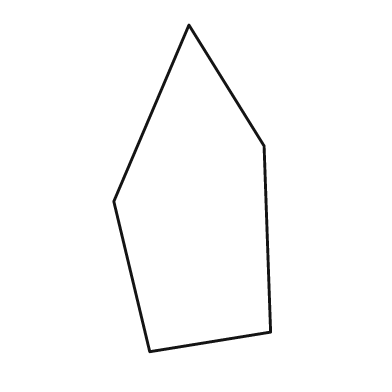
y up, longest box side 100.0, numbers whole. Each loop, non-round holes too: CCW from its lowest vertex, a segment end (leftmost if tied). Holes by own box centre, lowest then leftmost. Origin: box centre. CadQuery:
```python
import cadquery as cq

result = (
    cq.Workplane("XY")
    .moveTo(-13.0, -50.0)
    .lineTo(24.0, -44.0)
    .lineTo(22.0, 13.0)
    .lineTo(-1.0, 50.0)
    .lineTo(-24.0, -4.0)
    .close()
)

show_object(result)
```